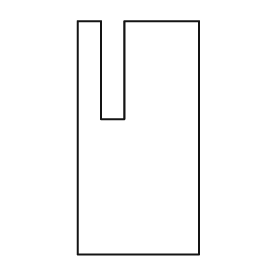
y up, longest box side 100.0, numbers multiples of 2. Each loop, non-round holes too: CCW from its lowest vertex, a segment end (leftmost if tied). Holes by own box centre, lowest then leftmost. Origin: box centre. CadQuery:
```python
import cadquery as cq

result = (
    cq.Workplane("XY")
    .moveTo(-26.0, -50.0)
    .lineTo(26.0, -50.0)
    .lineTo(26.0, 50.0)
    .lineTo(-6.0, 50.0)
    .lineTo(-6.0, 8.0)
    .lineTo(-16.0, 8.0)
    .lineTo(-16.0, 50.0)
    .lineTo(-26.0, 50.0)
    .close()
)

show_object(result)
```